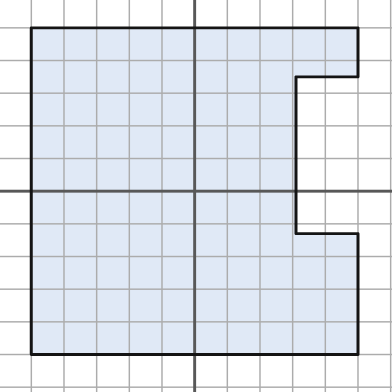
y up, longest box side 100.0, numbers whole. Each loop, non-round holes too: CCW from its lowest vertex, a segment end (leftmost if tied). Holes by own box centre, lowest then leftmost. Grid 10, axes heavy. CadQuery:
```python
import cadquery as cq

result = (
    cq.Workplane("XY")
    .moveTo(-50.0, -50.0)
    .lineTo(50.0, -50.0)
    .lineTo(50.0, -13.0)
    .lineTo(31.0, -13.0)
    .lineTo(31.0, 35.0)
    .lineTo(50.0, 35.0)
    .lineTo(50.0, 50.0)
    .lineTo(-50.0, 50.0)
    .close()
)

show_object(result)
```